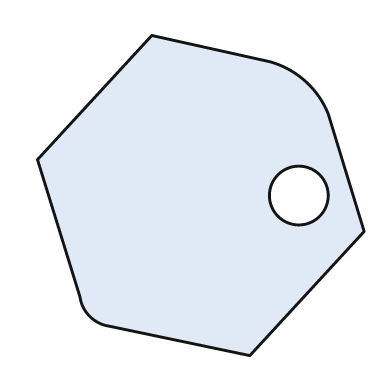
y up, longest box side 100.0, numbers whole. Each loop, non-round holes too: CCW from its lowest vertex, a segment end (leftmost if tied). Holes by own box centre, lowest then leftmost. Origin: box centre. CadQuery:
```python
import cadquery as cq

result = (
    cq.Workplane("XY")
    .moveTo(15.0, -49.0)
    .lineTo(50.0, -11.0)
    .lineTo(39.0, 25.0)
    .threePointArc((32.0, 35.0), (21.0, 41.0))
    .lineTo(-15.0, 49.0)
    .lineTo(-50.0, 11.0)
    .lineTo(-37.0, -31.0)
    .threePointArc((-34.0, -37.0), (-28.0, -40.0))
    .close()
    .moveTo(30.0, 0.0)
    .circle(9.0)
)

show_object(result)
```